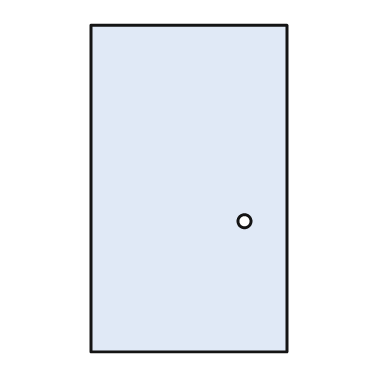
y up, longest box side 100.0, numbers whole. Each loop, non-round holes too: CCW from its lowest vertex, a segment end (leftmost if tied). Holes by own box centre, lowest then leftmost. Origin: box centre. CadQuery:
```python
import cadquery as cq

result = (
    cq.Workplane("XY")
    .moveTo(-30.0, -50.0)
    .lineTo(30.0, -50.0)
    .lineTo(30.0, 50.0)
    .lineTo(-30.0, 50.0)
    .close()
    .moveTo(17.0, -10.0)
    .circle(2.0)
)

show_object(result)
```